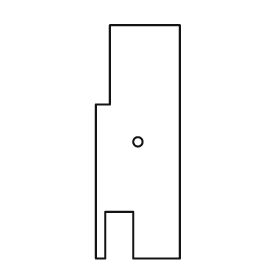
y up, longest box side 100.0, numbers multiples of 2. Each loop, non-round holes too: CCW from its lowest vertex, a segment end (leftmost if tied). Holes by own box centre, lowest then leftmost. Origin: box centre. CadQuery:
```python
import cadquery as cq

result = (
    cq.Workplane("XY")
    .moveTo(-18.0, -50.0)
    .lineTo(-14.0, -50.0)
    .lineTo(-14.0, -30.0)
    .lineTo(-2.0, -30.0)
    .lineTo(-2.0, -50.0)
    .lineTo(18.0, -50.0)
    .lineTo(18.0, 50.0)
    .lineTo(-12.0, 50.0)
    .lineTo(-12.0, 16.0)
    .lineTo(-18.0, 16.0)
    .close()
    .moveTo(0.0, 0.0)
    .circle(2.0)
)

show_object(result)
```